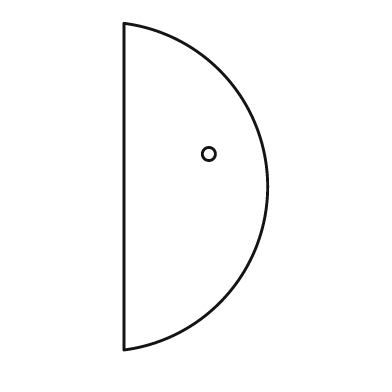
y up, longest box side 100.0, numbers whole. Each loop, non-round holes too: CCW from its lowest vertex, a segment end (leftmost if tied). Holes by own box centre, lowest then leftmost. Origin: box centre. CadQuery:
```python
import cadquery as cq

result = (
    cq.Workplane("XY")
    .moveTo(-22.0, -50.0)
    .threePointArc((22.0, 0.0), (-22.0, 50.0))
    .close()
    .moveTo(4.0, 10.0)
    .circle(2.0)
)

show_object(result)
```